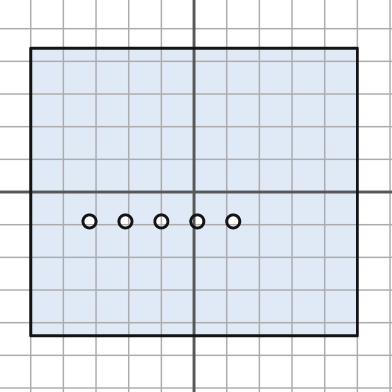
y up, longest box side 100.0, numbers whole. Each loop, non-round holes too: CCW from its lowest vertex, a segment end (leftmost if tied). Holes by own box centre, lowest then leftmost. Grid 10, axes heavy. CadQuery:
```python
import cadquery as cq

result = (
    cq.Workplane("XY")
    .moveTo(-50.0, -44.0)
    .lineTo(50.0, -44.0)
    .lineTo(50.0, 44.0)
    .lineTo(-50.0, 44.0)
    .close()
    .moveTo(-32.0, -9.0)
    .circle(2.0)
    .moveTo(-21.0, -9.0)
    .circle(2.0)
    .moveTo(-10.0, -9.0)
    .circle(2.0)
    .moveTo(1.0, -9.0)
    .circle(2.0)
    .moveTo(12.0, -9.0)
    .circle(2.0)
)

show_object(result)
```